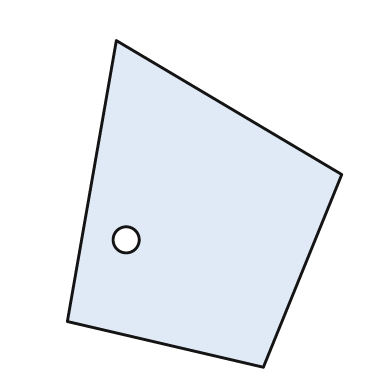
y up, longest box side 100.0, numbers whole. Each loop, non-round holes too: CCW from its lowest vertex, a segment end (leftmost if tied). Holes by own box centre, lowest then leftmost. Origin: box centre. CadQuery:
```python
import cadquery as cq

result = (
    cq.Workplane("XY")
    .moveTo(18.0, -50.0)
    .lineTo(42.0, 9.0)
    .lineTo(-27.0, 50.0)
    .lineTo(-42.0, -36.0)
    .close()
    .moveTo(-24.0, -11.0)
    .circle(4.0)
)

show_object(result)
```